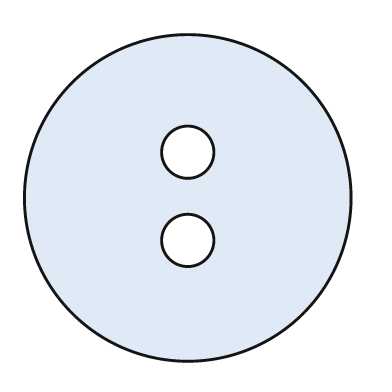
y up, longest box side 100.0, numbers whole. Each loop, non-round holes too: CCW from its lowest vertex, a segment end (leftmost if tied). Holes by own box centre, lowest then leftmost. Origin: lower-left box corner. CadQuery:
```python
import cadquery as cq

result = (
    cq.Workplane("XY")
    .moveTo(50.0, 50.0)
    .circle(50.0)
    .moveTo(50.0, 37.0)
    .circle(8.0)
    .moveTo(50.0, 64.0)
    .circle(8.0)
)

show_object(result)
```